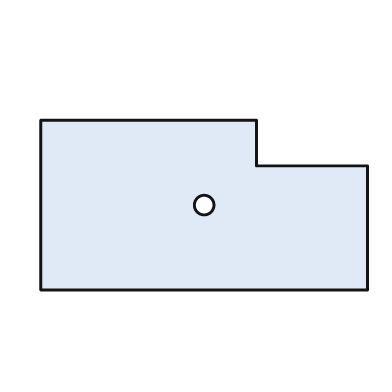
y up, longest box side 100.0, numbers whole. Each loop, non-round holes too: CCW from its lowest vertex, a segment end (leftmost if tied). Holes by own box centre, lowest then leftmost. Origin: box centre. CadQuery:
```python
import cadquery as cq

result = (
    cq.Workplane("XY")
    .moveTo(-50.0, -26.0)
    .lineTo(50.0, -26.0)
    .lineTo(50.0, 12.0)
    .lineTo(16.0, 12.0)
    .lineTo(16.0, 26.0)
    .lineTo(-50.0, 26.0)
    .close()
    .moveTo(0.0, 0.0)
    .circle(3.0)
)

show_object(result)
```